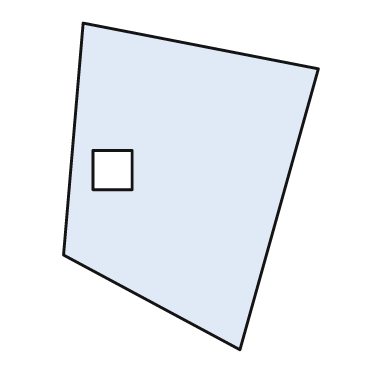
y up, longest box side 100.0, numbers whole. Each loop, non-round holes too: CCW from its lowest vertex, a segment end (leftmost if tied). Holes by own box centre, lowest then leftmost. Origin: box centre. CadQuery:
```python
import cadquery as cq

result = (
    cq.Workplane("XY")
    .moveTo(15.0, -50.0)
    .lineTo(39.0, 36.0)
    .lineTo(-33.0, 50.0)
    .lineTo(-39.0, -21.0)
    .close()
    .moveTo(-30.0, -1.0)
    .lineTo(-18.0, -1.0)
    .lineTo(-18.0, 11.0)
    .lineTo(-30.0, 11.0)
    .close()
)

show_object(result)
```